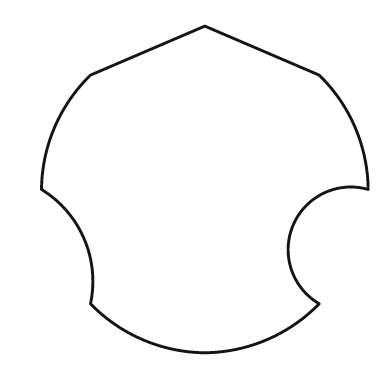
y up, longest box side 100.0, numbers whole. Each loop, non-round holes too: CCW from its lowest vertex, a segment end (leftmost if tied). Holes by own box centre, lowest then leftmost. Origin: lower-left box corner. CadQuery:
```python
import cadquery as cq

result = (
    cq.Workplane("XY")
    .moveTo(50.0, 0.0)
    .threePointArc((69.0, 4.0), (85.0, 15.0))
    .threePointArc((77.0, 39.0), (100.0, 50.0))
    .threePointArc((96.0, 69.0), (85.0, 85.0))
    .lineTo(50.0, 100.0)
    .lineTo(15.0, 85.0)
    .threePointArc((4.0, 69.0), (0.0, 50.0))
    .threePointArc((13.0, 35.0), (15.0, 15.0))
    .threePointArc((31.0, 4.0), (50.0, 0.0))
    .close()
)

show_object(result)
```